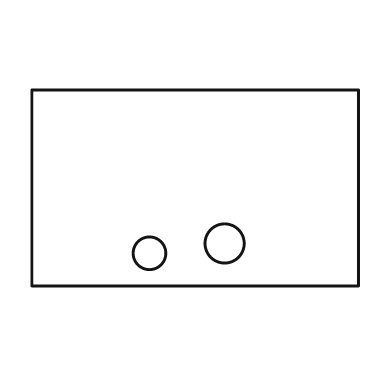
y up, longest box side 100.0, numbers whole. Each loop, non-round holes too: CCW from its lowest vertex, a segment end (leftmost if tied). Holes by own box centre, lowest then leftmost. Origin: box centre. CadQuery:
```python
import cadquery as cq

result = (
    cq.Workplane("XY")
    .moveTo(-50.0, -30.0)
    .lineTo(50.0, -30.0)
    .lineTo(50.0, 30.0)
    .lineTo(-50.0, 30.0)
    .close()
    .moveTo(-14.0, -20.0)
    .circle(5.0)
    .moveTo(9.0, -17.0)
    .circle(6.0)
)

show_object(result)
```